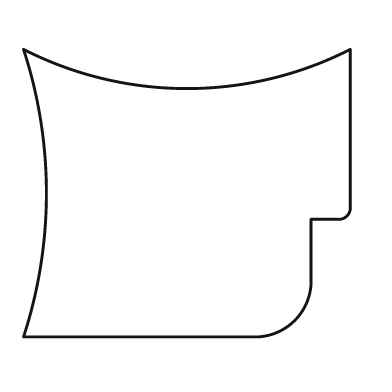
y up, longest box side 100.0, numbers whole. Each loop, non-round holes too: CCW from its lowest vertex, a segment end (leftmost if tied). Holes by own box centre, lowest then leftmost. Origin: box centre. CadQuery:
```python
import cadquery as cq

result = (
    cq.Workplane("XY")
    .moveTo(-50.0, -44.0)
    .lineTo(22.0, -44.0)
    .threePointArc((33.0, -39.0), (38.0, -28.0))
    .lineTo(38.0, -8.0)
    .lineTo(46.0, -8.0)
    .threePointArc((49.0, -7.0), (50.0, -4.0))
    .lineTo(50.0, 44.0)
    .threePointArc((0.0, 32.0), (-50.0, 44.0))
    .threePointArc((-43.0, 0.0), (-50.0, -44.0))
    .close()
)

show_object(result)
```